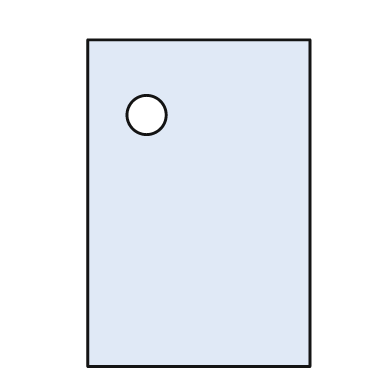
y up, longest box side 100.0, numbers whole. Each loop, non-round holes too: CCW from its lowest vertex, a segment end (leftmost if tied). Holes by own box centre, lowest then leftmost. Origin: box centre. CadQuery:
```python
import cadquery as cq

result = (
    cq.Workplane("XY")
    .moveTo(-34.0, -50.0)
    .lineTo(34.0, -50.0)
    .lineTo(34.0, 50.0)
    .lineTo(-34.0, 50.0)
    .close()
    .moveTo(-16.0, 27.0)
    .circle(6.0)
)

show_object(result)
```